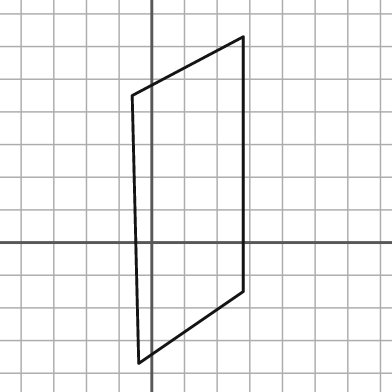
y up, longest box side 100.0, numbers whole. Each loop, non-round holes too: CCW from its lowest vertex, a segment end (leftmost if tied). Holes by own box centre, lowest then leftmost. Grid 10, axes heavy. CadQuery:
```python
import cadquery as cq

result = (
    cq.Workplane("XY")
    .moveTo(-4.0, -37.0)
    .lineTo(28.0, -15.0)
    .lineTo(28.0, 63.0)
    .lineTo(-6.0, 45.0)
    .close()
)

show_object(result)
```